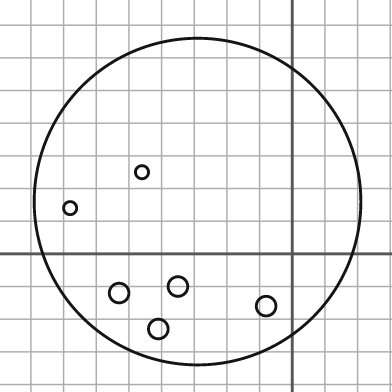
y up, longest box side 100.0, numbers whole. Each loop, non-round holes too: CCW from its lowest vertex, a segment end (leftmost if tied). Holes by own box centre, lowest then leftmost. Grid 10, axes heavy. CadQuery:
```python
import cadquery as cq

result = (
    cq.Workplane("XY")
    .moveTo(-29.0, 16.0)
    .circle(50.0)
    .moveTo(-41.0, -23.0)
    .circle(3.0)
    .moveTo(-8.0, -16.0)
    .circle(3.0)
    .moveTo(-53.0, -12.0)
    .circle(3.0)
    .moveTo(-35.0, -10.0)
    .circle(3.0)
    .moveTo(-68.0, 14.0)
    .circle(2.0)
    .moveTo(-46.0, 25.0)
    .circle(2.0)
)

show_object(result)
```